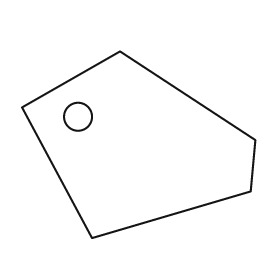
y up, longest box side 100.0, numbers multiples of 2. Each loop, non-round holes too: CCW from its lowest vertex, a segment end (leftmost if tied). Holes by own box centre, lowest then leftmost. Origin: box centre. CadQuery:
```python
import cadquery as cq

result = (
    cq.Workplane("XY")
    .moveTo(-20.0, -40.0)
    .lineTo(48.0, -20.0)
    .lineTo(50.0, 2.0)
    .lineTo(-8.0, 40.0)
    .lineTo(-50.0, 16.0)
    .close()
    .moveTo(-26.0, 12.0)
    .circle(6.0)
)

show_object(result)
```